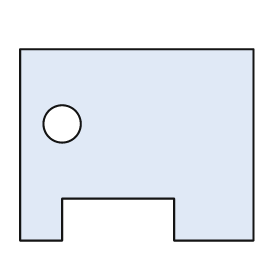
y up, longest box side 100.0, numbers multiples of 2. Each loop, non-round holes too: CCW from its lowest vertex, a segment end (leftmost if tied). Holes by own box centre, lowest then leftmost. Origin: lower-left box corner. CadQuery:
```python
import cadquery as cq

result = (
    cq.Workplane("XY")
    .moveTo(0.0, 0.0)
    .lineTo(18.0, 0.0)
    .lineTo(18.0, 18.0)
    .lineTo(66.0, 18.0)
    .lineTo(66.0, 0.0)
    .lineTo(100.0, 0.0)
    .lineTo(100.0, 82.0)
    .lineTo(0.0, 82.0)
    .close()
    .moveTo(18.0, 50.0)
    .circle(8.0)
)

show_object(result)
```